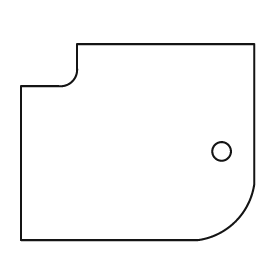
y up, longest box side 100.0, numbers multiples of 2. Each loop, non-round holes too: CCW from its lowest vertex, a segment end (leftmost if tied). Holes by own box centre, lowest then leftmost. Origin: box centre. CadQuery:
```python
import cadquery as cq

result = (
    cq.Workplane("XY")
    .moveTo(-50.0, -42.0)
    .lineTo(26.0, -42.0)
    .threePointArc((42.0, -34.0), (50.0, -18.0))
    .lineTo(50.0, 42.0)
    .lineTo(-26.0, 42.0)
    .lineTo(-26.0, 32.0)
    .threePointArc((-28.0, 26.0), (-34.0, 24.0))
    .lineTo(-50.0, 24.0)
    .close()
    .moveTo(36.0, -4.0)
    .circle(4.0)
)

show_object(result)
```